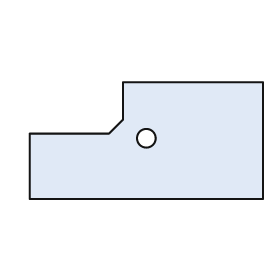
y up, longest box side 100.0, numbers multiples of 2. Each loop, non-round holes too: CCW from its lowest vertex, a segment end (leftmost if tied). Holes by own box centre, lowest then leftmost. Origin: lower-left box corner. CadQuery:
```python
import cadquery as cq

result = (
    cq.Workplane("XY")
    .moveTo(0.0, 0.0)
    .lineTo(100.0, 0.0)
    .lineTo(100.0, 50.0)
    .lineTo(40.0, 50.0)
    .lineTo(40.0, 34.0)
    .lineTo(34.0, 28.0)
    .lineTo(0.0, 28.0)
    .close()
    .moveTo(50.0, 26.0)
    .circle(4.0)
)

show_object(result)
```